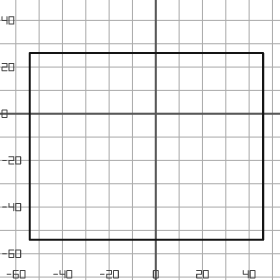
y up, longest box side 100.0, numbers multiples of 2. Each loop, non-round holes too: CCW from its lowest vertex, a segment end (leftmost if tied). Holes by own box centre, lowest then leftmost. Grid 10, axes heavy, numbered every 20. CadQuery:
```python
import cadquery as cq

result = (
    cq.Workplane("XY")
    .moveTo(-54.0, -54.0)
    .lineTo(46.0, -54.0)
    .lineTo(46.0, 26.0)
    .lineTo(-54.0, 26.0)
    .close()
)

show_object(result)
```